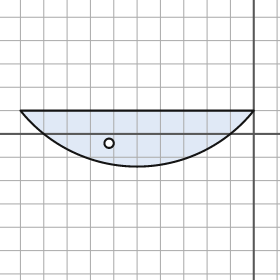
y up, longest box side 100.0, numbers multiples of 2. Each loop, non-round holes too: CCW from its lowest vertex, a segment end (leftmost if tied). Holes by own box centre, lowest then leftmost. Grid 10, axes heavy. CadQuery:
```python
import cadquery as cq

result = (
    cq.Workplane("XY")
    .moveTo(-100.0, 10.0)
    .threePointArc((-50.0, -14.0), (0.0, 10.0))
    .close()
    .moveTo(-62.0, -4.0)
    .circle(2.0)
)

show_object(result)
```